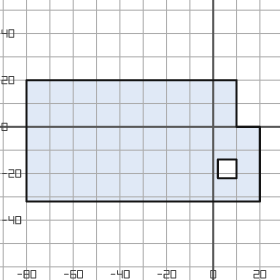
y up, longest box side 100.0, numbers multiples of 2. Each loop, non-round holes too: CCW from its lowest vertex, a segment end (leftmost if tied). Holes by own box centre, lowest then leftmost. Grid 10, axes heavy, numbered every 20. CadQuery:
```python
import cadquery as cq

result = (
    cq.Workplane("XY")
    .moveTo(-80.0, -32.0)
    .lineTo(20.0, -32.0)
    .lineTo(20.0, 0.0)
    .lineTo(10.0, 0.0)
    .lineTo(10.0, 20.0)
    .lineTo(-80.0, 20.0)
    .close()
    .moveTo(2.0, -22.0)
    .lineTo(10.0, -22.0)
    .lineTo(10.0, -14.0)
    .lineTo(2.0, -14.0)
    .close()
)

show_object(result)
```